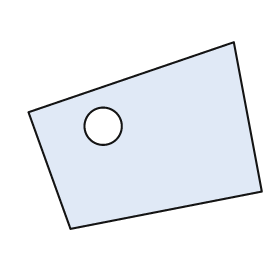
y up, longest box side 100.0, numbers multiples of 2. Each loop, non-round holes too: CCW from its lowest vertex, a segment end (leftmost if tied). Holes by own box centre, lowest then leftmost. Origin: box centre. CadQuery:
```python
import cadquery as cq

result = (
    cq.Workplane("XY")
    .moveTo(-32.0, -40.0)
    .lineTo(50.0, -24.0)
    .lineTo(38.0, 40.0)
    .lineTo(-50.0, 10.0)
    .close()
    .moveTo(-18.0, 4.0)
    .circle(8.0)
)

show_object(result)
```